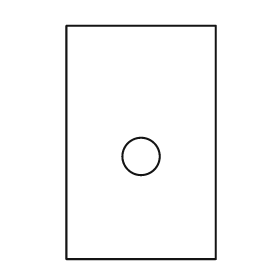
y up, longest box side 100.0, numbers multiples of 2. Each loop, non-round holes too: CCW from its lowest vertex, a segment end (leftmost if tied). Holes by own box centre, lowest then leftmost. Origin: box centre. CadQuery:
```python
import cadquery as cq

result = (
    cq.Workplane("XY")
    .moveTo(-32.0, -50.0)
    .lineTo(32.0, -50.0)
    .lineTo(32.0, 50.0)
    .lineTo(-32.0, 50.0)
    .close()
    .moveTo(0.0, -6.0)
    .circle(8.0)
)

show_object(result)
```